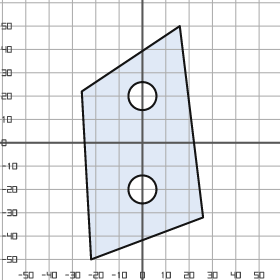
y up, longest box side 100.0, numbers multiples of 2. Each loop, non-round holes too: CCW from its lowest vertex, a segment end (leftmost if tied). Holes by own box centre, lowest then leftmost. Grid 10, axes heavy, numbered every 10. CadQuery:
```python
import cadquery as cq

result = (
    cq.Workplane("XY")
    .moveTo(-22.0, -50.0)
    .lineTo(26.0, -32.0)
    .lineTo(16.0, 50.0)
    .lineTo(-26.0, 22.0)
    .close()
    .moveTo(0.0, -20.0)
    .circle(6.0)
    .moveTo(0.0, 20.0)
    .circle(6.0)
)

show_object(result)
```